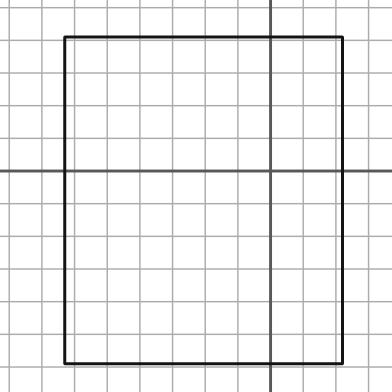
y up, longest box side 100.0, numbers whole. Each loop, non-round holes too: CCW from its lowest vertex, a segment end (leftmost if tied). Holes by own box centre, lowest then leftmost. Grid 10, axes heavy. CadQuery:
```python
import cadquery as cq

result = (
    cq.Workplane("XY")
    .moveTo(-63.0, -59.0)
    .lineTo(22.0, -59.0)
    .lineTo(22.0, 41.0)
    .lineTo(-63.0, 41.0)
    .close()
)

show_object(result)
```